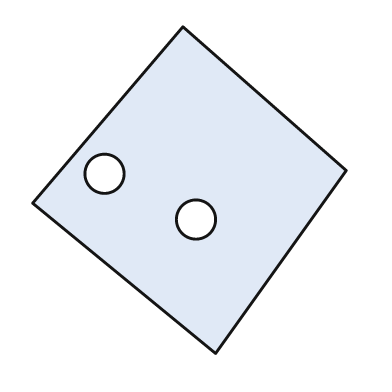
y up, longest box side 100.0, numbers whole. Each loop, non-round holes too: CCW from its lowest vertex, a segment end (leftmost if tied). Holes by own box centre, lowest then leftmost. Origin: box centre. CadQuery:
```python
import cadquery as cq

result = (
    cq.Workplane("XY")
    .moveTo(8.0, -50.0)
    .lineTo(48.0, 6.0)
    .lineTo(-2.0, 50.0)
    .lineTo(-48.0, -4.0)
    .close()
    .moveTo(2.0, -9.0)
    .circle(6.0)
    .moveTo(-26.0, 5.0)
    .circle(6.0)
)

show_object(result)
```